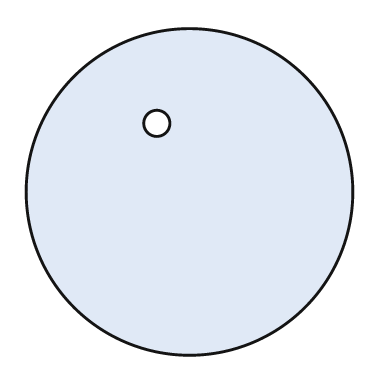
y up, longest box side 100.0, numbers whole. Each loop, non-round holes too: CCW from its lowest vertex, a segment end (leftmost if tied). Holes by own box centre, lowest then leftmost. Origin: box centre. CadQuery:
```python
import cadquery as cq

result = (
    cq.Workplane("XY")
    .moveTo(0.0, 0.0)
    .circle(50.0)
    .moveTo(-10.0, 21.0)
    .circle(4.0)
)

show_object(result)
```